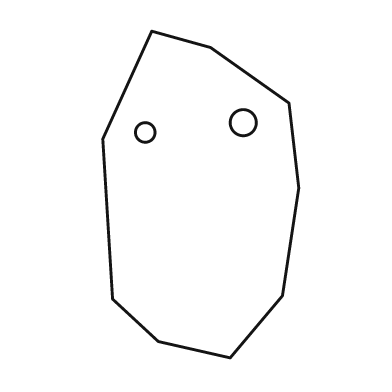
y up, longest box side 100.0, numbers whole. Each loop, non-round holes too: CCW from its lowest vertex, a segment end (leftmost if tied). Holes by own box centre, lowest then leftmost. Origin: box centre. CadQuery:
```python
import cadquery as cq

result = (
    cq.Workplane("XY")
    .moveTo(9.0, -50.0)
    .lineTo(25.0, -31.0)
    .lineTo(30.0, 2.0)
    .lineTo(27.0, 28.0)
    .lineTo(3.0, 45.0)
    .lineTo(-15.0, 50.0)
    .lineTo(-30.0, 17.0)
    .lineTo(-27.0, -32.0)
    .lineTo(-13.0, -45.0)
    .close()
    .moveTo(-17.0, 19.0)
    .circle(3.0)
    .moveTo(13.0, 22.0)
    .circle(4.0)
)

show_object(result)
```